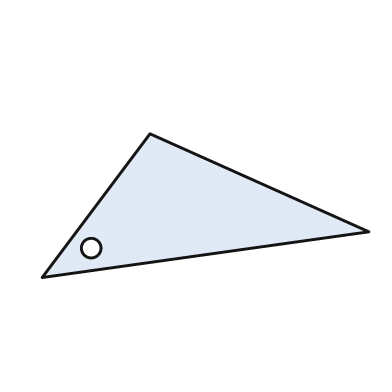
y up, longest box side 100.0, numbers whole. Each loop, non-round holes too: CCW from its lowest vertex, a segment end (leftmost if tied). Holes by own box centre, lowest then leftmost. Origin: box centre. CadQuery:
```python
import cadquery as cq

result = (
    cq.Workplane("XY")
    .moveTo(-50.0, -22.0)
    .lineTo(50.0, -8.0)
    .lineTo(-17.0, 22.0)
    .close()
    .moveTo(-35.0, -13.0)
    .circle(3.0)
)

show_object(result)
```